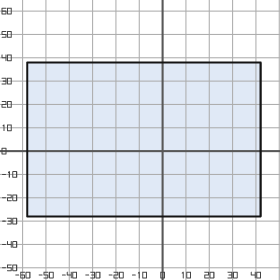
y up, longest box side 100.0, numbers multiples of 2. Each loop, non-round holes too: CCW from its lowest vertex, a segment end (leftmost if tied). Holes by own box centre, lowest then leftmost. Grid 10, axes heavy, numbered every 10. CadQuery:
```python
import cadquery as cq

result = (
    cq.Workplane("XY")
    .moveTo(-58.0, -28.0)
    .lineTo(42.0, -28.0)
    .lineTo(42.0, 38.0)
    .lineTo(-58.0, 38.0)
    .close()
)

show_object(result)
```